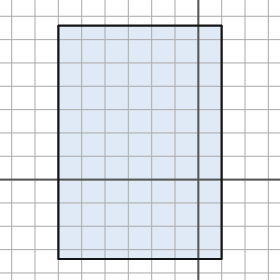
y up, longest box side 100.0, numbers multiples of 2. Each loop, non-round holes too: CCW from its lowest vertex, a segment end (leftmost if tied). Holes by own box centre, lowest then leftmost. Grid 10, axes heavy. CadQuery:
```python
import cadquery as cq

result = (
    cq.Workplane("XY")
    .moveTo(-60.0, -34.0)
    .lineTo(10.0, -34.0)
    .lineTo(10.0, 66.0)
    .lineTo(-60.0, 66.0)
    .close()
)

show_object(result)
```